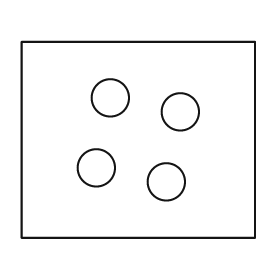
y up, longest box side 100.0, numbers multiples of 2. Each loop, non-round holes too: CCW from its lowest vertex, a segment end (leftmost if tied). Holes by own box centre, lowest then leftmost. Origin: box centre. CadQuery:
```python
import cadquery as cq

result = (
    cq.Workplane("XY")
    .moveTo(-50.0, -42.0)
    .lineTo(50.0, -42.0)
    .lineTo(50.0, 42.0)
    .lineTo(-50.0, 42.0)
    .close()
    .moveTo(12.0, -18.0)
    .circle(8.0)
    .moveTo(-18.0, -12.0)
    .circle(8.0)
    .moveTo(18.0, 12.0)
    .circle(8.0)
    .moveTo(-12.0, 18.0)
    .circle(8.0)
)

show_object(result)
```